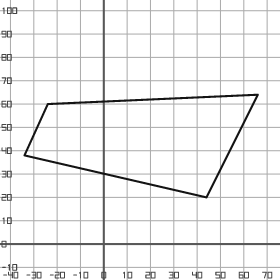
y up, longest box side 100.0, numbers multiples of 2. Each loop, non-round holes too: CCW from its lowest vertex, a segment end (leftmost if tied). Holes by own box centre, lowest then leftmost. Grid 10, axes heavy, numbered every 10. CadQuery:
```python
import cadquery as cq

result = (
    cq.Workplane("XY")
    .moveTo(44.0, 20.0)
    .lineTo(66.0, 64.0)
    .lineTo(-24.0, 60.0)
    .lineTo(-34.0, 38.0)
    .close()
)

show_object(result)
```